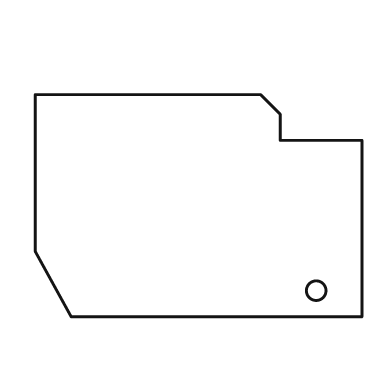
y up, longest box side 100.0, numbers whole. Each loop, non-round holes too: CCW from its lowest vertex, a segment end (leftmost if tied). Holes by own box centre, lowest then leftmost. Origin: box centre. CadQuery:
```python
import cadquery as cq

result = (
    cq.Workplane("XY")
    .moveTo(-39.0, -34.0)
    .lineTo(50.0, -34.0)
    .lineTo(50.0, 20.0)
    .lineTo(25.0, 20.0)
    .lineTo(25.0, 28.0)
    .lineTo(19.0, 34.0)
    .lineTo(-50.0, 34.0)
    .lineTo(-50.0, -14.0)
    .close()
    .moveTo(36.0, -26.0)
    .circle(3.0)
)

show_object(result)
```